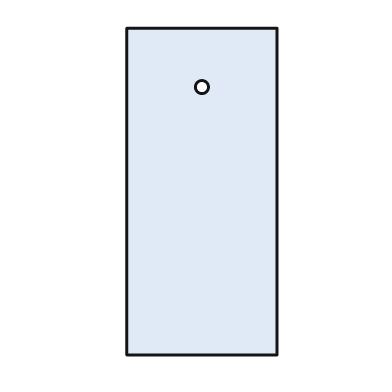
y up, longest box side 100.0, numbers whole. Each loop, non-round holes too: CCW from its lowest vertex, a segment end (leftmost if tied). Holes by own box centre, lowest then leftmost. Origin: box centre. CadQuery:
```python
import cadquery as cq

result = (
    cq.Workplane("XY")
    .moveTo(-23.0, -50.0)
    .lineTo(23.0, -50.0)
    .lineTo(23.0, 50.0)
    .lineTo(-23.0, 50.0)
    .close()
    .moveTo(0.0, 32.0)
    .circle(2.0)
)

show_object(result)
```